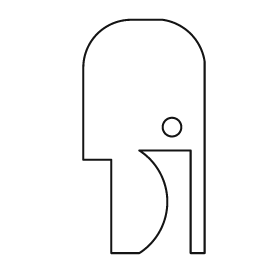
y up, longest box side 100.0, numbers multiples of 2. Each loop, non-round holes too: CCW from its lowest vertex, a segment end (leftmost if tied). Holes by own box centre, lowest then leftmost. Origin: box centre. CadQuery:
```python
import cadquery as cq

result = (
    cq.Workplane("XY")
    .moveTo(-14.0, -50.0)
    .lineTo(-2.0, -50.0)
    .threePointArc((10.0, -28.0), (-2.0, -6.0))
    .lineTo(20.0, -6.0)
    .lineTo(20.0, -50.0)
    .lineTo(26.0, -50.0)
    .lineTo(26.0, 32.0)
    .threePointArc((20.0, 44.0), (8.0, 50.0))
    .lineTo(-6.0, 50.0)
    .threePointArc((-20.0, 44.0), (-26.0, 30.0))
    .lineTo(-26.0, -10.0)
    .lineTo(-14.0, -10.0)
    .close()
    .moveTo(12.0, 4.0)
    .circle(4.0)
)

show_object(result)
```